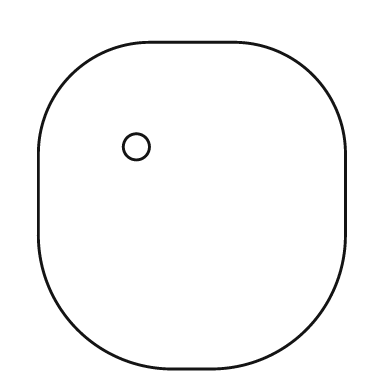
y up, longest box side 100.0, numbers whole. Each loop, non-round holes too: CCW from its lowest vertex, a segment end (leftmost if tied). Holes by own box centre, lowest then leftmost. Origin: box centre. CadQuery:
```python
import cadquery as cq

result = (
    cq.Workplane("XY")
    .moveTo(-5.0, -50.0)
    .lineTo(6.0, -50.0)
    .threePointArc((35.0, -38.0), (47.0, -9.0))
    .lineTo(47.0, 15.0)
    .threePointArc((37.0, 40.0), (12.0, 50.0))
    .lineTo(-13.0, 50.0)
    .threePointArc((-37.0, 40.0), (-47.0, 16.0))
    .lineTo(-47.0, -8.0)
    .threePointArc((-35.0, -38.0), (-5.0, -50.0))
    .close()
    .moveTo(-17.0, 18.0)
    .circle(4.0)
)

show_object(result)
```